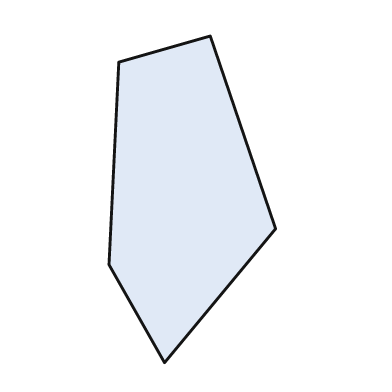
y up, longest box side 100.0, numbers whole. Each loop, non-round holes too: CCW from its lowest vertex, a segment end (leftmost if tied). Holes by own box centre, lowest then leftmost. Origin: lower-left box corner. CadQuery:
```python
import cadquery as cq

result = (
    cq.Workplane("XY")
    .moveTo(17.0, 0.0)
    .lineTo(51.0, 41.0)
    .lineTo(31.0, 100.0)
    .lineTo(3.0, 92.0)
    .lineTo(0.0, 30.0)
    .close()
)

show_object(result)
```